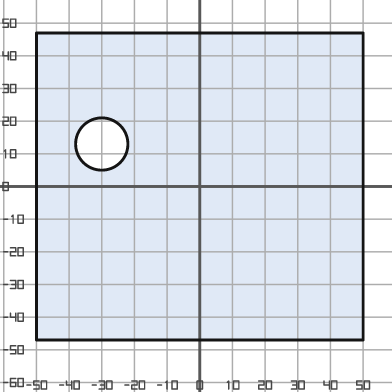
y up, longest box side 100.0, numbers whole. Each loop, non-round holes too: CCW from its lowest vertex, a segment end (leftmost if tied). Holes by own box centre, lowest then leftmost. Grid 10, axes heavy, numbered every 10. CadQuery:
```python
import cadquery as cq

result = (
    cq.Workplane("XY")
    .moveTo(-50.0, -47.0)
    .lineTo(50.0, -47.0)
    .lineTo(50.0, 47.0)
    .lineTo(-50.0, 47.0)
    .close()
    .moveTo(-30.0, 13.0)
    .circle(8.0)
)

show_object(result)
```